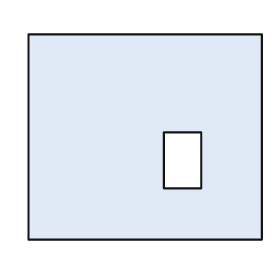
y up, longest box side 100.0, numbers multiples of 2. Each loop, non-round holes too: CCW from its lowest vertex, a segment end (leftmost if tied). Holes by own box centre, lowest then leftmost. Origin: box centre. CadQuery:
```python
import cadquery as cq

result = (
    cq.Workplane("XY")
    .moveTo(-50.0, -44.0)
    .lineTo(50.0, -44.0)
    .lineTo(50.0, 44.0)
    .lineTo(-50.0, 44.0)
    .close()
    .moveTo(8.0, -22.0)
    .lineTo(24.0, -22.0)
    .lineTo(24.0, 2.0)
    .lineTo(8.0, 2.0)
    .close()
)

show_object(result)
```